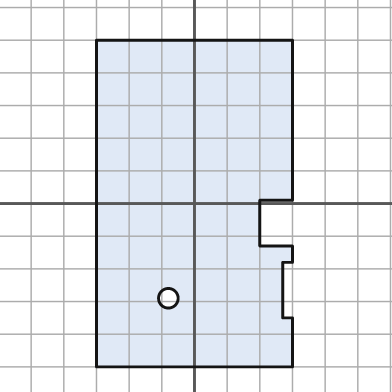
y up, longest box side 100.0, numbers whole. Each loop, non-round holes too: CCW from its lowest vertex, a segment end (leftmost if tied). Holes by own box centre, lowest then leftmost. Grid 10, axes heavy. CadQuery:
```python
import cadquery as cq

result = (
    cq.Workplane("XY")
    .moveTo(-30.0, -50.0)
    .lineTo(30.0, -50.0)
    .lineTo(30.0, -35.0)
    .lineTo(27.0, -35.0)
    .lineTo(27.0, -18.0)
    .lineTo(30.0, -18.0)
    .lineTo(30.0, -13.0)
    .lineTo(20.0, -13.0)
    .lineTo(20.0, 1.0)
    .lineTo(30.0, 1.0)
    .lineTo(30.0, 50.0)
    .lineTo(-30.0, 50.0)
    .close()
    .moveTo(-8.0, -29.0)
    .circle(3.0)
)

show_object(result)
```